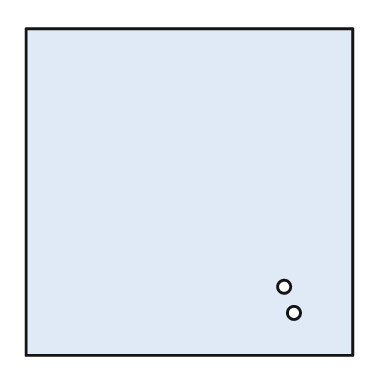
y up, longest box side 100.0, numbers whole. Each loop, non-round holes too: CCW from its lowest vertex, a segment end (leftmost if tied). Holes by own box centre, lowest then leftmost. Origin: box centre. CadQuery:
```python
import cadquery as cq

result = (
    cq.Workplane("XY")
    .moveTo(-50.0, -50.0)
    .lineTo(50.0, -50.0)
    .lineTo(50.0, 50.0)
    .lineTo(-50.0, 50.0)
    .close()
    .moveTo(32.0, -37.0)
    .circle(2.0)
    .moveTo(29.0, -29.0)
    .circle(2.0)
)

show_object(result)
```